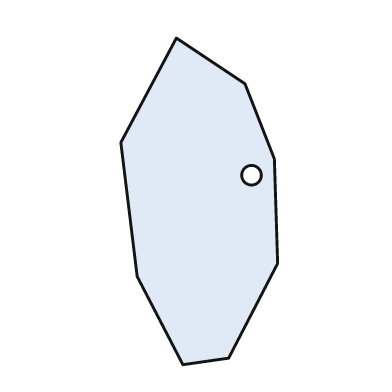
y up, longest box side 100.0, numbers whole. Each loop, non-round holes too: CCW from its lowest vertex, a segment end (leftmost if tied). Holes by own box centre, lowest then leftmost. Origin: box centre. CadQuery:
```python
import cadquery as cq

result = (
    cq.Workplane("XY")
    .moveTo(-5.0, -50.0)
    .lineTo(9.0, -48.0)
    .lineTo(24.0, -19.0)
    .lineTo(23.0, 13.0)
    .lineTo(14.0, 36.0)
    .lineTo(-7.0, 50.0)
    .lineTo(-24.0, 18.0)
    .lineTo(-19.0, -23.0)
    .close()
    .moveTo(16.0, 8.0)
    .circle(3.0)
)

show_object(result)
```